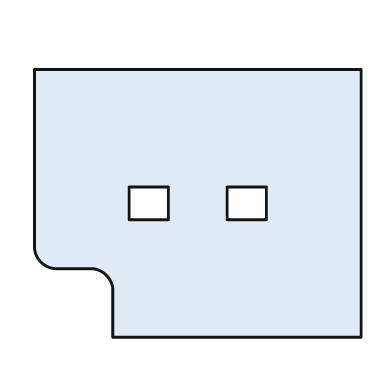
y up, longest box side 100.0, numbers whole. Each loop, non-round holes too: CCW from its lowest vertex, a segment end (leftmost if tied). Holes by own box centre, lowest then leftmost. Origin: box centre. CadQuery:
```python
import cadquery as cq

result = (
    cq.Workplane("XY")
    .moveTo(-26.0, -41.0)
    .lineTo(50.0, -41.0)
    .lineTo(50.0, 41.0)
    .lineTo(-50.0, 41.0)
    .lineTo(-50.0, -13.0)
    .threePointArc((-48.0, -18.0), (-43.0, -20.0))
    .lineTo(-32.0, -20.0)
    .threePointArc((-28.0, -22.0), (-26.0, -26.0))
    .close()
    .moveTo(-21.0, -5.0)
    .lineTo(-9.0, -5.0)
    .lineTo(-9.0, 5.0)
    .lineTo(-21.0, 5.0)
    .close()
    .moveTo(9.0, -5.0)
    .lineTo(21.0, -5.0)
    .lineTo(21.0, 5.0)
    .lineTo(9.0, 5.0)
    .close()
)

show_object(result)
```